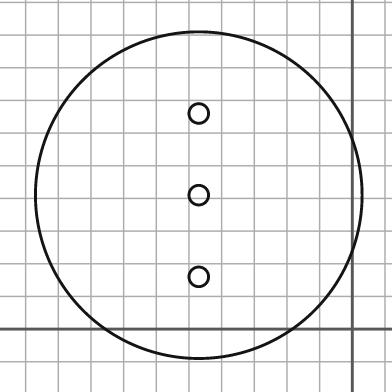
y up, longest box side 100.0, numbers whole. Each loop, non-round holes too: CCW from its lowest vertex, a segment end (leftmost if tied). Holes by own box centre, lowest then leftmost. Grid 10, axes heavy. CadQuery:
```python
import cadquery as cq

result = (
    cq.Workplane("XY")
    .moveTo(-47.0, 41.0)
    .circle(50.0)
    .moveTo(-47.0, 16.0)
    .circle(3.0)
    .moveTo(-47.0, 41.0)
    .circle(3.0)
    .moveTo(-47.0, 66.0)
    .circle(3.0)
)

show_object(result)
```